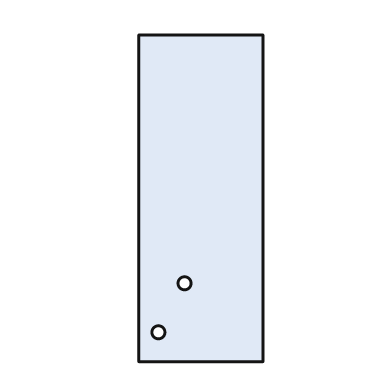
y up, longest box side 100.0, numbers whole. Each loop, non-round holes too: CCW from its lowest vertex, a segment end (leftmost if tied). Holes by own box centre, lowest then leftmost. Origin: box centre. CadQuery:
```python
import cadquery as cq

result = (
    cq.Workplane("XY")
    .moveTo(-19.0, -50.0)
    .lineTo(19.0, -50.0)
    .lineTo(19.0, 50.0)
    .lineTo(-19.0, 50.0)
    .close()
    .moveTo(-13.0, -41.0)
    .circle(2.0)
    .moveTo(-5.0, -26.0)
    .circle(2.0)
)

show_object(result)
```